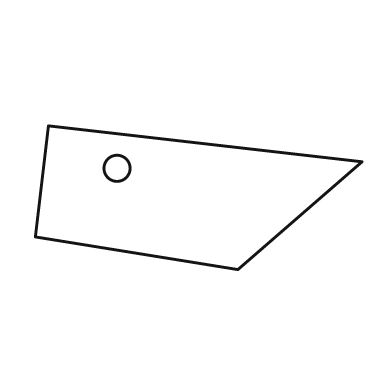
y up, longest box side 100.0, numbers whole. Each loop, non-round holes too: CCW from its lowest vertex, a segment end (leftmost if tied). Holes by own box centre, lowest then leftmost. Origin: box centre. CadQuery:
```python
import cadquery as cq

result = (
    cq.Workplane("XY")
    .moveTo(12.0, -22.0)
    .lineTo(50.0, 11.0)
    .lineTo(-46.0, 22.0)
    .lineTo(-50.0, -12.0)
    .close()
    .moveTo(-25.0, 9.0)
    .circle(4.0)
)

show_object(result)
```